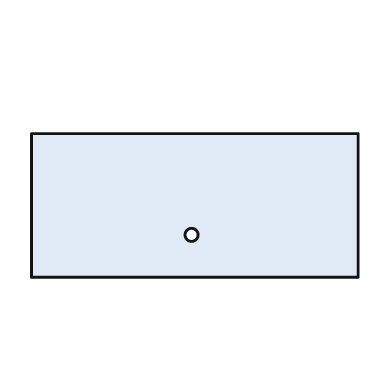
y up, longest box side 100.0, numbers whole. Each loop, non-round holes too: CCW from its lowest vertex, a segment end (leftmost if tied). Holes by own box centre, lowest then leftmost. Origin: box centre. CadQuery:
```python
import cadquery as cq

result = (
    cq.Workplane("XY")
    .moveTo(-50.0, -22.0)
    .lineTo(50.0, -22.0)
    .lineTo(50.0, 22.0)
    .lineTo(-50.0, 22.0)
    .close()
    .moveTo(-1.0, -9.0)
    .circle(2.0)
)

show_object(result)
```